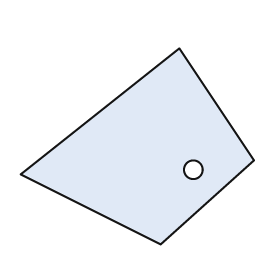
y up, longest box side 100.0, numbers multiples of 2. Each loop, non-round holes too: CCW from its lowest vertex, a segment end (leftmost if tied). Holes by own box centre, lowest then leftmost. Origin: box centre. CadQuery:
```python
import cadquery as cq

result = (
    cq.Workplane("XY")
    .moveTo(10.0, -42.0)
    .lineTo(50.0, -6.0)
    .lineTo(18.0, 42.0)
    .lineTo(-50.0, -12.0)
    .close()
    .moveTo(24.0, -10.0)
    .circle(4.0)
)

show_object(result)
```